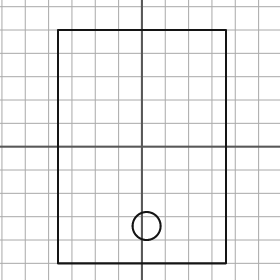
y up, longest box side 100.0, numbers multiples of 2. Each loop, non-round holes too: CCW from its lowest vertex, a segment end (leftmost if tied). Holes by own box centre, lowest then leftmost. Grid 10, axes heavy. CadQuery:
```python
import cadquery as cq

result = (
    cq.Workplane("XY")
    .moveTo(-36.0, -50.0)
    .lineTo(36.0, -50.0)
    .lineTo(36.0, 50.0)
    .lineTo(-36.0, 50.0)
    .close()
    .moveTo(2.0, -34.0)
    .circle(6.0)
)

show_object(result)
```